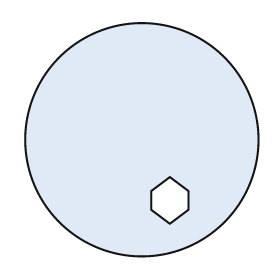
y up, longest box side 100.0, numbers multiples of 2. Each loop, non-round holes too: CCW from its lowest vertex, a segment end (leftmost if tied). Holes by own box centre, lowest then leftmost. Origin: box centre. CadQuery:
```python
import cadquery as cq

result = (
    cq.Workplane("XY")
    .moveTo(0.0, 0.0)
    .circle(50.0)
    .moveTo(12.0, -36.0)
    .lineTo(20.0, -30.0)
    .lineTo(20.0, -22.0)
    .lineTo(12.0, -16.0)
    .lineTo(4.0, -22.0)
    .lineTo(4.0, -30.0)
    .close()
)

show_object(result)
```